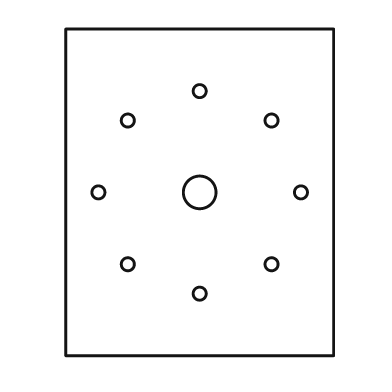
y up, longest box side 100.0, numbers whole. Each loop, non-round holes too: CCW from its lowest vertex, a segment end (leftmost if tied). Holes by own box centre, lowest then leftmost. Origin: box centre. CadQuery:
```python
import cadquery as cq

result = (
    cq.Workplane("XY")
    .moveTo(-41.0, -50.0)
    .lineTo(41.0, -50.0)
    .lineTo(41.0, 50.0)
    .lineTo(-41.0, 50.0)
    .close()
    .moveTo(0.0, -31.0)
    .circle(2.0)
    .moveTo(-22.0, -22.0)
    .circle(2.0)
    .moveTo(22.0, -22.0)
    .circle(2.0)
    .moveTo(-31.0, 0.0)
    .circle(2.0)
    .moveTo(0.0, 0.0)
    .circle(5.0)
    .moveTo(31.0, 0.0)
    .circle(2.0)
    .moveTo(-22.0, 22.0)
    .circle(2.0)
    .moveTo(22.0, 22.0)
    .circle(2.0)
    .moveTo(0.0, 31.0)
    .circle(2.0)
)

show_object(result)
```